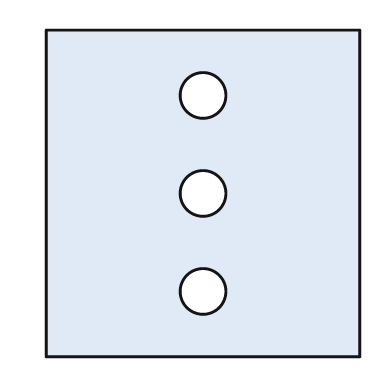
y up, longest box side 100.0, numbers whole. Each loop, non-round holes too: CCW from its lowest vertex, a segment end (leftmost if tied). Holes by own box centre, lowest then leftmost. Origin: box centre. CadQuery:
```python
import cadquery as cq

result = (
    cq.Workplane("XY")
    .moveTo(-48.0, -50.0)
    .lineTo(48.0, -50.0)
    .lineTo(48.0, 50.0)
    .lineTo(-48.0, 50.0)
    .close()
    .moveTo(0.0, -30.0)
    .circle(7.0)
    .moveTo(0.0, 0.0)
    .circle(7.0)
    .moveTo(0.0, 30.0)
    .circle(7.0)
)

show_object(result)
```